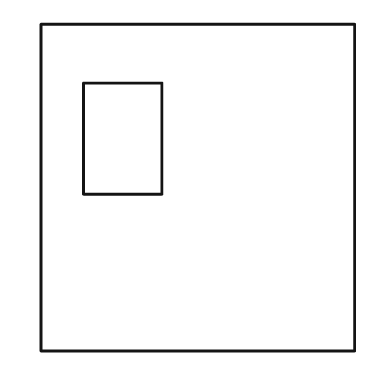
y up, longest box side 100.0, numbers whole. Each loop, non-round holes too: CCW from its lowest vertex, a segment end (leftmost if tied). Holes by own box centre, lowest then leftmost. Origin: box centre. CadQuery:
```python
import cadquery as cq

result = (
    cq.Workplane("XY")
    .moveTo(-48.0, -50.0)
    .lineTo(48.0, -50.0)
    .lineTo(48.0, 50.0)
    .lineTo(-48.0, 50.0)
    .close()
    .moveTo(-35.0, -2.0)
    .lineTo(-11.0, -2.0)
    .lineTo(-11.0, 32.0)
    .lineTo(-35.0, 32.0)
    .close()
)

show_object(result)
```